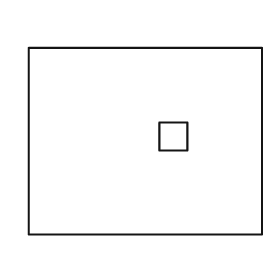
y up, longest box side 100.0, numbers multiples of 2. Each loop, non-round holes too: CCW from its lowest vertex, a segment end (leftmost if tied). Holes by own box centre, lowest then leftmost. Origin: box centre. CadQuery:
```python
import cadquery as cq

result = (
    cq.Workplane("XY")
    .moveTo(-50.0, -40.0)
    .lineTo(50.0, -40.0)
    .lineTo(50.0, 40.0)
    .lineTo(-50.0, 40.0)
    .close()
    .moveTo(6.0, -4.0)
    .lineTo(18.0, -4.0)
    .lineTo(18.0, 8.0)
    .lineTo(6.0, 8.0)
    .close()
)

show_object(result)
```